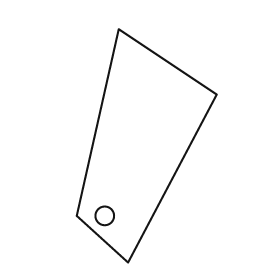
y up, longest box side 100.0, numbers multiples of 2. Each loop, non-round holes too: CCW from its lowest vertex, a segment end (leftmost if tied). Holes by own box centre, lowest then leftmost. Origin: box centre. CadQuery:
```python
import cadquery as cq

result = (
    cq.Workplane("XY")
    .moveTo(-8.0, -50.0)
    .lineTo(30.0, 22.0)
    .lineTo(-12.0, 50.0)
    .lineTo(-30.0, -30.0)
    .close()
    .moveTo(-18.0, -30.0)
    .circle(4.0)
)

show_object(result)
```